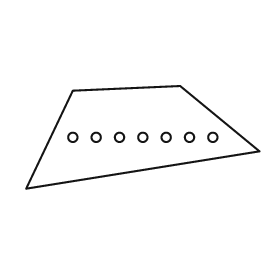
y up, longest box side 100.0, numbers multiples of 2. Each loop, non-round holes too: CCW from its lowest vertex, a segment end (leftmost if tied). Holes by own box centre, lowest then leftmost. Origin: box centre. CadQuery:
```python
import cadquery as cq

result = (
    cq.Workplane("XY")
    .moveTo(-50.0, -22.0)
    .lineTo(50.0, -6.0)
    .lineTo(16.0, 22.0)
    .lineTo(-30.0, 20.0)
    .close()
    .moveTo(-30.0, 0.0)
    .circle(2.0)
    .moveTo(-20.0, 0.0)
    .circle(2.0)
    .moveTo(-10.0, 0.0)
    .circle(2.0)
    .moveTo(0.0, 0.0)
    .circle(2.0)
    .moveTo(10.0, 0.0)
    .circle(2.0)
    .moveTo(20.0, 0.0)
    .circle(2.0)
    .moveTo(30.0, 0.0)
    .circle(2.0)
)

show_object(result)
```